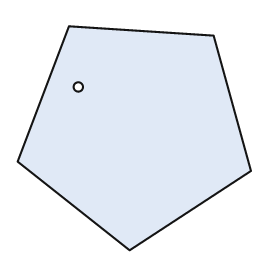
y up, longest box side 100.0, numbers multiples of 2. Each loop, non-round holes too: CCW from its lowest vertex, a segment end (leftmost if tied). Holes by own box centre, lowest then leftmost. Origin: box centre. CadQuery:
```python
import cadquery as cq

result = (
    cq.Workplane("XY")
    .moveTo(-2.0, -48.0)
    .lineTo(50.0, -14.0)
    .lineTo(34.0, 44.0)
    .lineTo(-28.0, 48.0)
    .lineTo(-50.0, -10.0)
    .close()
    .moveTo(-24.0, 22.0)
    .circle(2.0)
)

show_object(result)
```